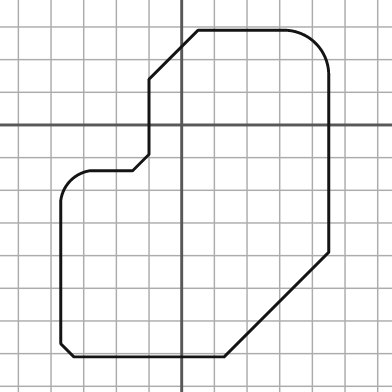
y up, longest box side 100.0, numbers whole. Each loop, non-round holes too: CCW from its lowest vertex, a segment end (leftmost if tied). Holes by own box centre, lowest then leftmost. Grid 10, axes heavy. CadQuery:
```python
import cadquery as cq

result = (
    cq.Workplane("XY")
    .moveTo(-33.0, -71.0)
    .lineTo(13.0, -71.0)
    .lineTo(45.0, -39.0)
    .lineTo(45.0, 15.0)
    .threePointArc((41.0, 25.0), (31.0, 29.0))
    .lineTo(5.0, 29.0)
    .lineTo(-10.0, 14.0)
    .lineTo(-10.0, -9.0)
    .lineTo(-15.0, -14.0)
    .lineTo(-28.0, -14.0)
    .threePointArc((-34.0, -17.0), (-37.0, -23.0))
    .lineTo(-37.0, -67.0)
    .close()
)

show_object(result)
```